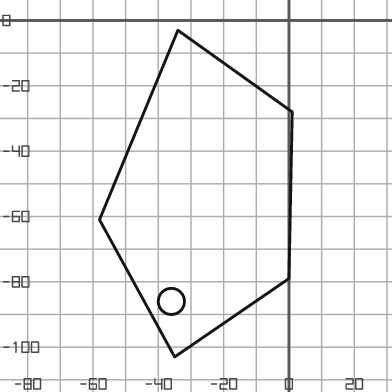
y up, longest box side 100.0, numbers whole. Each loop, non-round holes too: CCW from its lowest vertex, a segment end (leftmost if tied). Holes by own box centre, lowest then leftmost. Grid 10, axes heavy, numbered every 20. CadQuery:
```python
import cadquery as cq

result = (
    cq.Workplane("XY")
    .moveTo(-35.0, -103.0)
    .lineTo(0.0, -79.0)
    .lineTo(1.0, -28.0)
    .lineTo(-34.0, -3.0)
    .lineTo(-58.0, -61.0)
    .close()
    .moveTo(-36.0, -86.0)
    .circle(4.0)
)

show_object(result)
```